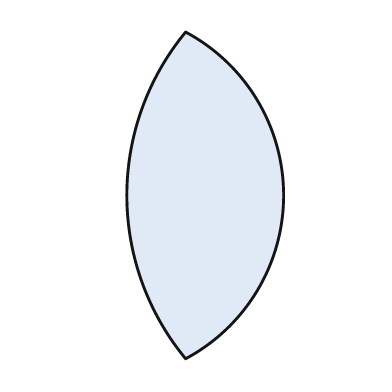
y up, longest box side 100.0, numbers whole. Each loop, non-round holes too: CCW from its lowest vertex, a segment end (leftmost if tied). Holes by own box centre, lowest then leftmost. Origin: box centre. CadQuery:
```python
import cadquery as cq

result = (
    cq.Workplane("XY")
    .moveTo(-6.0, -50.0)
    .threePointArc((24.0, 0.0), (-6.0, 50.0))
    .threePointArc((-24.0, 0.0), (-6.0, -50.0))
    .close()
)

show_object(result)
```